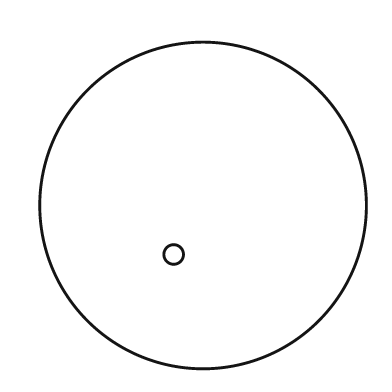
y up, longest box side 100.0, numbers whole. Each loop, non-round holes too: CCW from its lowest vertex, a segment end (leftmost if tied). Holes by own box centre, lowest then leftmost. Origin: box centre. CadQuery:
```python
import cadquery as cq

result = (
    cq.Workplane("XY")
    .moveTo(0.0, 0.0)
    .circle(50.0)
    .moveTo(-9.0, -15.0)
    .circle(3.0)
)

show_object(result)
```